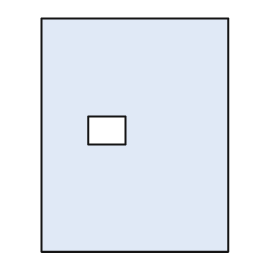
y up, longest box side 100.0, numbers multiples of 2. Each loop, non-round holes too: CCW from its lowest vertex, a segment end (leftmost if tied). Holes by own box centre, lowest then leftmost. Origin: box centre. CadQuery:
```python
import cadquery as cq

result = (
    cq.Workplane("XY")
    .moveTo(-40.0, -50.0)
    .lineTo(40.0, -50.0)
    .lineTo(40.0, 50.0)
    .lineTo(-40.0, 50.0)
    .close()
    .moveTo(-20.0, -4.0)
    .lineTo(-4.0, -4.0)
    .lineTo(-4.0, 8.0)
    .lineTo(-20.0, 8.0)
    .close()
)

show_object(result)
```